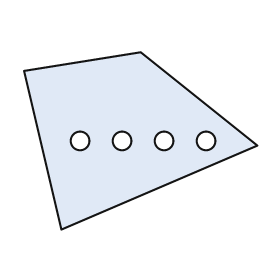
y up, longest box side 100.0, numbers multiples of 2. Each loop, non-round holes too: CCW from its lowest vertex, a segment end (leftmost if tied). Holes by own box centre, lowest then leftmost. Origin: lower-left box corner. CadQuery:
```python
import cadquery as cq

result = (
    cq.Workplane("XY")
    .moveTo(16.0, 0.0)
    .lineTo(100.0, 36.0)
    .lineTo(50.0, 76.0)
    .lineTo(0.0, 68.0)
    .close()
    .moveTo(24.0, 38.0)
    .circle(4.0)
    .moveTo(42.0, 38.0)
    .circle(4.0)
    .moveTo(60.0, 38.0)
    .circle(4.0)
    .moveTo(78.0, 38.0)
    .circle(4.0)
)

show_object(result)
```